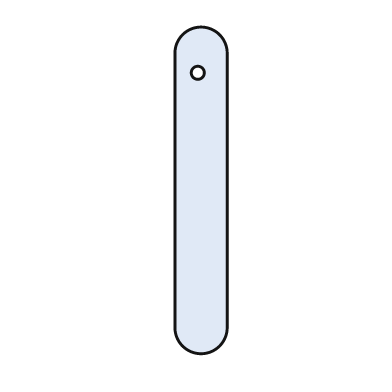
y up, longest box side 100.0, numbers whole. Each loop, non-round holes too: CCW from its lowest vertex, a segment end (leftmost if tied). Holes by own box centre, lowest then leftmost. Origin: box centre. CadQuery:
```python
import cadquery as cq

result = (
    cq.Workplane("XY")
    .moveTo(-8.0, -42.0)
    .threePointArc((0.0, -50.0), (8.0, -42.0))
    .lineTo(8.0, 42.0)
    .threePointArc((0.0, 50.0), (-8.0, 42.0))
    .close()
    .moveTo(-1.0, 36.0)
    .circle(2.0)
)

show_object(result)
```